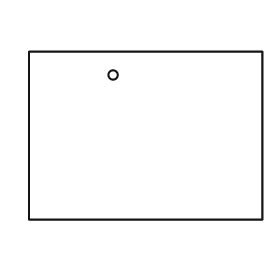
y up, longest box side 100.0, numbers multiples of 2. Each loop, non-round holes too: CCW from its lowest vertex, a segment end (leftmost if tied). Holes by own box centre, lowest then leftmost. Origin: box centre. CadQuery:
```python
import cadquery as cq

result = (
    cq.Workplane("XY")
    .moveTo(-50.0, -36.0)
    .lineTo(50.0, -36.0)
    .lineTo(50.0, 36.0)
    .lineTo(-50.0, 36.0)
    .close()
    .moveTo(-14.0, 26.0)
    .circle(2.0)
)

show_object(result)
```